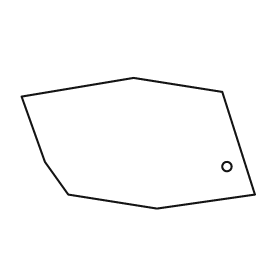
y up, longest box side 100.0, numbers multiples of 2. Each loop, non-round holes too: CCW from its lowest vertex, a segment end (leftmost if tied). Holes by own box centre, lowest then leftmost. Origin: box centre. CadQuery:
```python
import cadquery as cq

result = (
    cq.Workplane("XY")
    .moveTo(8.0, -28.0)
    .lineTo(50.0, -22.0)
    .lineTo(36.0, 22.0)
    .lineTo(-2.0, 28.0)
    .lineTo(-50.0, 20.0)
    .lineTo(-40.0, -8.0)
    .lineTo(-30.0, -22.0)
    .close()
    .moveTo(38.0, -10.0)
    .circle(2.0)
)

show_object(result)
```